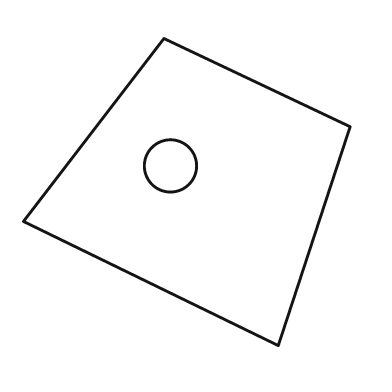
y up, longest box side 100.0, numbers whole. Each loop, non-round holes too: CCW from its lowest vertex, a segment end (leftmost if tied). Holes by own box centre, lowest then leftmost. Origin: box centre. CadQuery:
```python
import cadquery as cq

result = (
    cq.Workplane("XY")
    .moveTo(28.0, -47.0)
    .lineTo(50.0, 20.0)
    .lineTo(-7.0, 47.0)
    .lineTo(-50.0, -9.0)
    .close()
    .moveTo(-5.0, 8.0)
    .circle(8.0)
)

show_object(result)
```